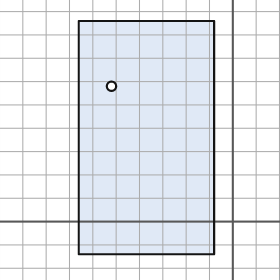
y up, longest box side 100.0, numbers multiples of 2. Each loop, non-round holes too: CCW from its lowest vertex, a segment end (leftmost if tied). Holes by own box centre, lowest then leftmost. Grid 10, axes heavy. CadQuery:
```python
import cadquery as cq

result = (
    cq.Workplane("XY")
    .moveTo(-66.0, -14.0)
    .lineTo(-8.0, -14.0)
    .lineTo(-8.0, 86.0)
    .lineTo(-66.0, 86.0)
    .close()
    .moveTo(-52.0, 58.0)
    .circle(2.0)
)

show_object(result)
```